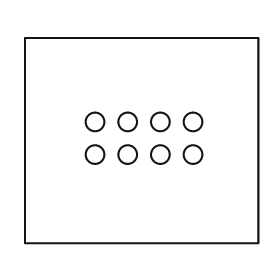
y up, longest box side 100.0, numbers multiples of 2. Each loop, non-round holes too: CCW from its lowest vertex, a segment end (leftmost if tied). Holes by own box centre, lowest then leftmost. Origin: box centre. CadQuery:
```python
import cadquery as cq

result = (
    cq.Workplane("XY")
    .moveTo(-50.0, -44.0)
    .lineTo(50.0, -44.0)
    .lineTo(50.0, 44.0)
    .lineTo(-50.0, 44.0)
    .close()
    .moveTo(-20.0, -6.0)
    .circle(4.0)
    .moveTo(-6.0, -6.0)
    .circle(4.0)
    .moveTo(8.0, -6.0)
    .circle(4.0)
    .moveTo(22.0, -6.0)
    .circle(4.0)
    .moveTo(-20.0, 8.0)
    .circle(4.0)
    .moveTo(-6.0, 8.0)
    .circle(4.0)
    .moveTo(8.0, 8.0)
    .circle(4.0)
    .moveTo(22.0, 8.0)
    .circle(4.0)
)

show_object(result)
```